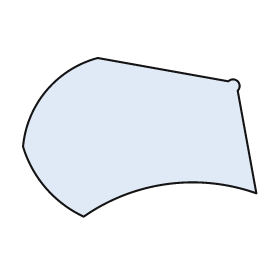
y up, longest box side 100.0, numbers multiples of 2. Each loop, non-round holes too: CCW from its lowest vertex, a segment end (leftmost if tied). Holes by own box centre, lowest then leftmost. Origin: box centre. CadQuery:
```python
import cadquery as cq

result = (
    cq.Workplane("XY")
    .moveTo(-24.0, -34.0)
    .threePointArc((12.0, -20.0), (50.0, -24.0))
    .lineTo(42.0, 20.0)
    .threePointArc((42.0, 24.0), (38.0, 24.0))
    .lineTo(-18.0, 34.0)
    .threePointArc((-40.0, 20.0), (-50.0, -4.0))
    .threePointArc((-40.0, -22.0), (-24.0, -34.0))
    .close()
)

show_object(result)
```